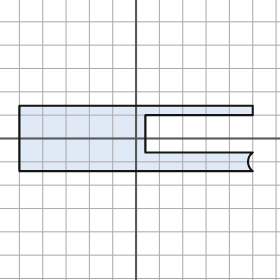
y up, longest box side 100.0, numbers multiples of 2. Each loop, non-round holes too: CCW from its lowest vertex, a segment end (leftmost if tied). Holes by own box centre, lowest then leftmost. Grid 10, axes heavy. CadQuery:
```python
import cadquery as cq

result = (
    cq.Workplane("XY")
    .moveTo(-50.0, -14.0)
    .lineTo(50.0, -14.0)
    .threePointArc((48.0, -10.0), (50.0, -6.0))
    .lineTo(4.0, -6.0)
    .lineTo(4.0, 10.0)
    .lineTo(50.0, 10.0)
    .lineTo(50.0, 14.0)
    .lineTo(-50.0, 14.0)
    .close()
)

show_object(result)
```